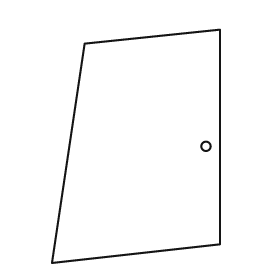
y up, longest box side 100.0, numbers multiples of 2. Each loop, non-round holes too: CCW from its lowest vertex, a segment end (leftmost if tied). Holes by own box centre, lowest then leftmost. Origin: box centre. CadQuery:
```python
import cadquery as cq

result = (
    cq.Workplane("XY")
    .moveTo(-36.0, -50.0)
    .lineTo(36.0, -42.0)
    .lineTo(36.0, 50.0)
    .lineTo(-22.0, 44.0)
    .close()
    .moveTo(30.0, 0.0)
    .circle(2.0)
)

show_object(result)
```